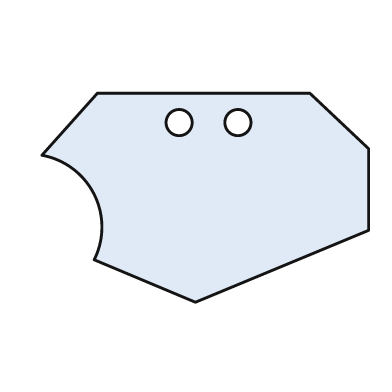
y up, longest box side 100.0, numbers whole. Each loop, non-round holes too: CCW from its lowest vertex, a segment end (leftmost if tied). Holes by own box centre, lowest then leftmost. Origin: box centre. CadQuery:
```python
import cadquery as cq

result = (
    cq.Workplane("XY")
    .moveTo(-3.0, -32.0)
    .lineTo(50.0, -10.0)
    .lineTo(50.0, 15.0)
    .lineTo(32.0, 32.0)
    .lineTo(-33.0, 32.0)
    .lineTo(-50.0, 13.0)
    .threePointArc((-34.0, 1.0), (-34.0, -19.0))
    .close()
    .moveTo(-8.0, 23.0)
    .circle(4.0)
    .moveTo(10.0, 23.0)
    .circle(4.0)
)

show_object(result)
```